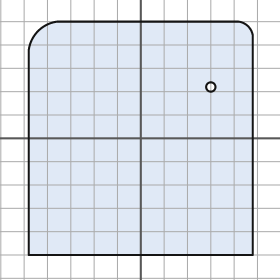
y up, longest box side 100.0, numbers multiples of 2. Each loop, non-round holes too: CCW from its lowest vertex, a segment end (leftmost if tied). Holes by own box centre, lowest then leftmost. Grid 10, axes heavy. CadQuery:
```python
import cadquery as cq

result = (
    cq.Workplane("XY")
    .moveTo(-48.0, -50.0)
    .lineTo(48.0, -50.0)
    .lineTo(48.0, 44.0)
    .threePointArc((46.0, 48.0), (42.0, 50.0))
    .lineTo(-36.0, 50.0)
    .threePointArc((-44.0, 46.0), (-48.0, 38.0))
    .close()
    .moveTo(30.0, 22.0)
    .circle(2.0)
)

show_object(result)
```